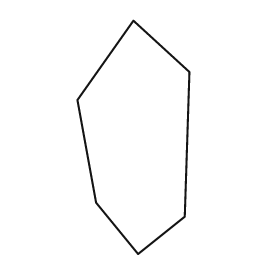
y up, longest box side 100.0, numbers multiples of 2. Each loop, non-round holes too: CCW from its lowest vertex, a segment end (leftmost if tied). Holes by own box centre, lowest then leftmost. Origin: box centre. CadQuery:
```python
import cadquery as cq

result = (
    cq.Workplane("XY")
    .moveTo(2.0, -50.0)
    .lineTo(22.0, -34.0)
    .lineTo(24.0, 28.0)
    .lineTo(0.0, 50.0)
    .lineTo(-24.0, 16.0)
    .lineTo(-16.0, -28.0)
    .close()
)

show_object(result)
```